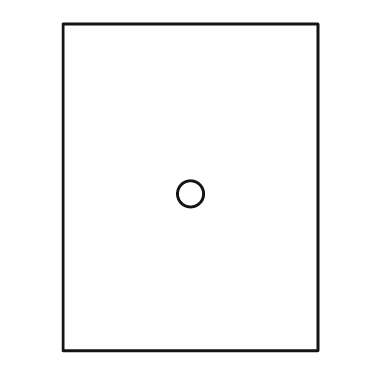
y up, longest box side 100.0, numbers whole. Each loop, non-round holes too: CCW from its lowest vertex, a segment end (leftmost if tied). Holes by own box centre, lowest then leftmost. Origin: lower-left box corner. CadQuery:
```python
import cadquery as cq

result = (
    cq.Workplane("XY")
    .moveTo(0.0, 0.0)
    .lineTo(78.0, 0.0)
    .lineTo(78.0, 100.0)
    .lineTo(0.0, 100.0)
    .close()
    .moveTo(39.0, 48.0)
    .circle(4.0)
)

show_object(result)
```